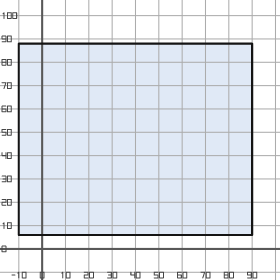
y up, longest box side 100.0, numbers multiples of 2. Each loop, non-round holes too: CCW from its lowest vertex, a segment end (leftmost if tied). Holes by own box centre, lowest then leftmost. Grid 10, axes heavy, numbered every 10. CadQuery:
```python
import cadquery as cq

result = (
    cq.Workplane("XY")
    .moveTo(-10.0, 6.0)
    .lineTo(90.0, 6.0)
    .lineTo(90.0, 88.0)
    .lineTo(-10.0, 88.0)
    .close()
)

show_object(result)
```